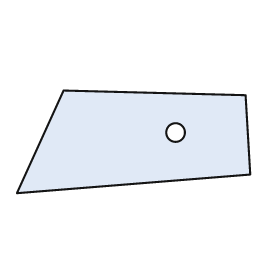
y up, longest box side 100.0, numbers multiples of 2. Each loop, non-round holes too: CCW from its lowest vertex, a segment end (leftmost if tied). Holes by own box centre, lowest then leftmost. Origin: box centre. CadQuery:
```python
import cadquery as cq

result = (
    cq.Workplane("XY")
    .moveTo(-50.0, -22.0)
    .lineTo(50.0, -14.0)
    .lineTo(48.0, 20.0)
    .lineTo(-30.0, 22.0)
    .close()
    .moveTo(18.0, 4.0)
    .circle(4.0)
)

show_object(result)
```